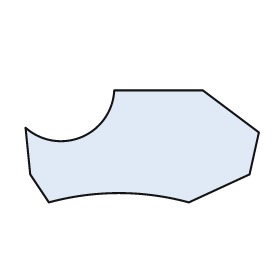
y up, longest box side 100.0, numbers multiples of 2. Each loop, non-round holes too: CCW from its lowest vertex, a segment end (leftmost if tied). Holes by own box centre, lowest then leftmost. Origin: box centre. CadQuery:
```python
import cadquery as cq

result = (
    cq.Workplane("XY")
    .moveTo(-40.0, -24.0)
    .threePointArc((-10.0, -20.0), (20.0, -24.0))
    .lineTo(46.0, -12.0)
    .lineTo(50.0, 6.0)
    .lineTo(26.0, 24.0)
    .lineTo(-12.0, 24.0)
    .threePointArc((-26.0, 4.0), (-50.0, 8.0))
    .lineTo(-48.0, -12.0)
    .close()
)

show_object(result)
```